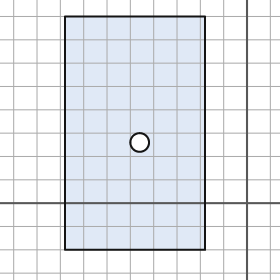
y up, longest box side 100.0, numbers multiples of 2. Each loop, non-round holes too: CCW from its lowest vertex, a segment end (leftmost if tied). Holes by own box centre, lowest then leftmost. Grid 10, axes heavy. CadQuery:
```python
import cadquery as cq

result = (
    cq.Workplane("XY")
    .moveTo(-78.0, -20.0)
    .lineTo(-18.0, -20.0)
    .lineTo(-18.0, 80.0)
    .lineTo(-78.0, 80.0)
    .close()
    .moveTo(-46.0, 26.0)
    .circle(4.0)
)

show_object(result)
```